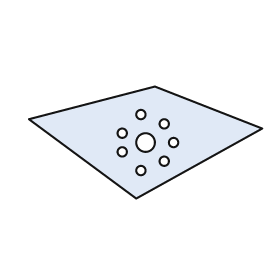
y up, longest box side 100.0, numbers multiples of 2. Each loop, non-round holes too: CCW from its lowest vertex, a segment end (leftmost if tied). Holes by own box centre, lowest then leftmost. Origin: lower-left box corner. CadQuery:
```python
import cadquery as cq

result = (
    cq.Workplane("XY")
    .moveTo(46.0, 0.0)
    .lineTo(100.0, 30.0)
    .lineTo(54.0, 48.0)
    .lineTo(0.0, 34.0)
    .close()
    .moveTo(48.0, 12.0)
    .circle(2.0)
    .moveTo(58.0, 16.0)
    .circle(2.0)
    .moveTo(40.0, 20.0)
    .circle(2.0)
    .moveTo(50.0, 24.0)
    .circle(4.0)
    .moveTo(62.0, 24.0)
    .circle(2.0)
    .moveTo(40.0, 28.0)
    .circle(2.0)
    .moveTo(58.0, 32.0)
    .circle(2.0)
    .moveTo(48.0, 36.0)
    .circle(2.0)
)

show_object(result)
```